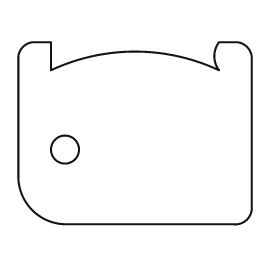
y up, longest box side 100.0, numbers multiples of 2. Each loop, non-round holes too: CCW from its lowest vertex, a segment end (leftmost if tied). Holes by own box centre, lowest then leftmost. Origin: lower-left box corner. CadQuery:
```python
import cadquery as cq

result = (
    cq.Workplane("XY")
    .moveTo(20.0, 0.0)
    .lineTo(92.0, 0.0)
    .threePointArc((98.0, 2.0), (100.0, 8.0))
    .lineTo(100.0, 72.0)
    .threePointArc((98.0, 76.0), (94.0, 78.0))
    .lineTo(86.0, 78.0)
    .threePointArc((84.0, 72.0), (86.0, 66.0))
    .threePointArc((50.0, 74.0), (14.0, 66.0))
    .lineTo(14.0, 78.0)
    .lineTo(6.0, 78.0)
    .threePointArc((2.0, 76.0), (0.0, 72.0))
    .lineTo(0.0, 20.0)
    .threePointArc((6.0, 6.0), (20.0, 0.0))
    .close()
    .moveTo(20.0, 32.0)
    .circle(6.0)
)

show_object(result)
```